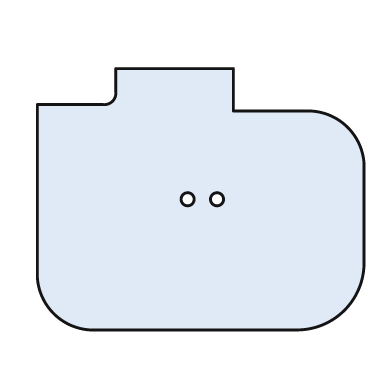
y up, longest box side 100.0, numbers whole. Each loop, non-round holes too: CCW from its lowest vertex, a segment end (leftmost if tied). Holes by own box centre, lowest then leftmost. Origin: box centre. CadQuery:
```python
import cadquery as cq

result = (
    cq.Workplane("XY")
    .moveTo(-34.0, -40.0)
    .lineTo(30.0, -40.0)
    .threePointArc((44.0, -34.0), (50.0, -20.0))
    .lineTo(50.0, 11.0)
    .threePointArc((45.0, 22.0), (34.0, 27.0))
    .lineTo(10.0, 27.0)
    .lineTo(10.0, 40.0)
    .lineTo(-26.0, 40.0)
    .lineTo(-26.0, 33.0)
    .threePointArc((-27.0, 30.0), (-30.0, 29.0))
    .lineTo(-50.0, 29.0)
    .lineTo(-50.0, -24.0)
    .threePointArc((-45.0, -35.0), (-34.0, -40.0))
    .close()
    .moveTo(-4.0, 0.0)
    .circle(2.0)
    .moveTo(5.0, 0.0)
    .circle(2.0)
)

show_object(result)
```